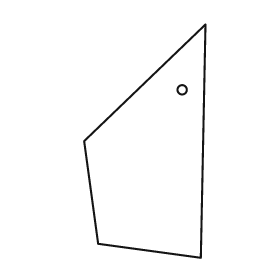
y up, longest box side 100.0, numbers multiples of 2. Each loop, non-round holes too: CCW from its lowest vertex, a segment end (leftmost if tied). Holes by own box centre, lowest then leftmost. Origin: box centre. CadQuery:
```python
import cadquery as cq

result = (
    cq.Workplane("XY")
    .moveTo(24.0, -50.0)
    .lineTo(26.0, 50.0)
    .lineTo(-26.0, 0.0)
    .lineTo(-20.0, -44.0)
    .close()
    .moveTo(16.0, 22.0)
    .circle(2.0)
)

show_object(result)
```